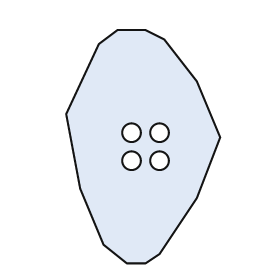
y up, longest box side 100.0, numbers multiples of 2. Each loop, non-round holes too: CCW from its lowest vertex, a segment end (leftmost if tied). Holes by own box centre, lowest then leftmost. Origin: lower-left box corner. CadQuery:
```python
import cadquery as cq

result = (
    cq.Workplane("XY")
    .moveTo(26.0, 0.0)
    .lineTo(34.0, 0.0)
    .lineTo(40.0, 4.0)
    .lineTo(56.0, 28.0)
    .lineTo(66.0, 54.0)
    .lineTo(56.0, 78.0)
    .lineTo(42.0, 96.0)
    .lineTo(34.0, 100.0)
    .lineTo(22.0, 100.0)
    .lineTo(14.0, 94.0)
    .lineTo(0.0, 64.0)
    .lineTo(6.0, 32.0)
    .lineTo(16.0, 8.0)
    .close()
    .moveTo(28.0, 44.0)
    .circle(4.0)
    .moveTo(40.0, 44.0)
    .circle(4.0)
    .moveTo(28.0, 56.0)
    .circle(4.0)
    .moveTo(40.0, 56.0)
    .circle(4.0)
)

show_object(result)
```